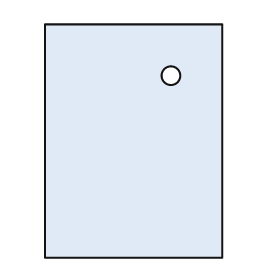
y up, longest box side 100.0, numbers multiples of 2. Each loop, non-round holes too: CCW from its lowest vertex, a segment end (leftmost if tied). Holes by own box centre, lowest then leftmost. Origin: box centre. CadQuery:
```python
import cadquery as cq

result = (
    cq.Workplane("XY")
    .moveTo(-38.0, -50.0)
    .lineTo(38.0, -50.0)
    .lineTo(38.0, 50.0)
    .lineTo(-38.0, 50.0)
    .close()
    .moveTo(16.0, 28.0)
    .circle(4.0)
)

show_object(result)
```